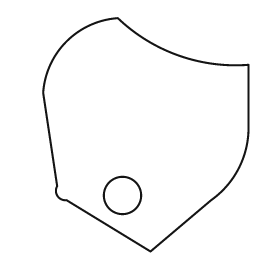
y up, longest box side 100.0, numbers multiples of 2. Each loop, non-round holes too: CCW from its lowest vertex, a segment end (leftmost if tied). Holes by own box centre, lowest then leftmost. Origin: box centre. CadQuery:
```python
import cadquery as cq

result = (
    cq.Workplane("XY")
    .moveTo(2.0, -50.0)
    .lineTo(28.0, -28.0)
    .threePointArc((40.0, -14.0), (44.0, 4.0))
    .lineTo(44.0, 30.0)
    .threePointArc((14.0, 34.0), (-12.0, 50.0))
    .threePointArc((-34.0, 40.0), (-44.0, 18.0))
    .lineTo(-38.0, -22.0)
    .threePointArc((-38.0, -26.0), (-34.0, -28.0))
    .close()
    .moveTo(-10.0, -26.0)
    .circle(8.0)
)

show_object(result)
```